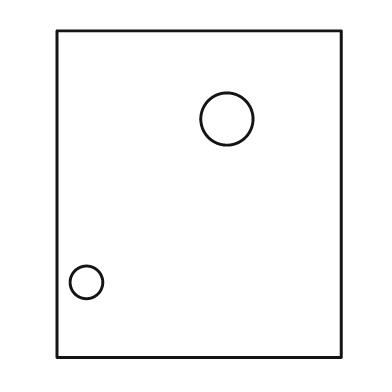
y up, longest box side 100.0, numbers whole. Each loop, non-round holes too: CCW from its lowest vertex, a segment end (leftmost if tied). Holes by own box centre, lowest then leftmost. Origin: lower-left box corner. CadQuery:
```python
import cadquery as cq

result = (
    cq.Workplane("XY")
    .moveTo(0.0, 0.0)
    .lineTo(87.0, 0.0)
    .lineTo(87.0, 100.0)
    .lineTo(0.0, 100.0)
    .close()
    .moveTo(9.0, 23.0)
    .circle(5.0)
    .moveTo(52.0, 73.0)
    .circle(8.0)
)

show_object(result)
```